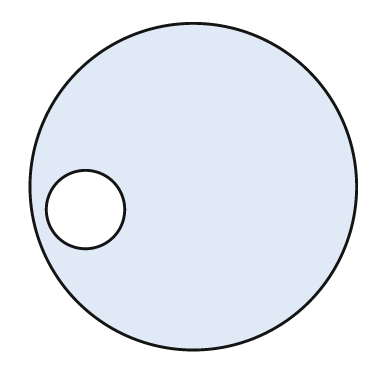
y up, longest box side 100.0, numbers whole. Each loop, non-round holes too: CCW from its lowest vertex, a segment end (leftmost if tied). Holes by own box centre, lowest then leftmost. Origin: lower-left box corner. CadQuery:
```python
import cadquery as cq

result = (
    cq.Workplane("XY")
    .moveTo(50.0, 50.0)
    .circle(50.0)
    .moveTo(17.0, 43.0)
    .circle(12.0)
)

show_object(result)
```